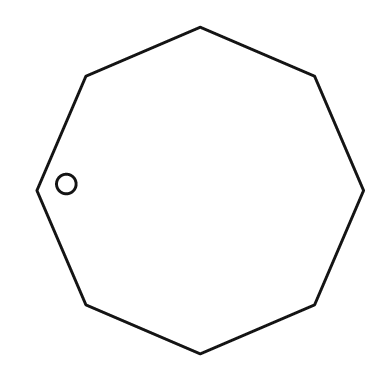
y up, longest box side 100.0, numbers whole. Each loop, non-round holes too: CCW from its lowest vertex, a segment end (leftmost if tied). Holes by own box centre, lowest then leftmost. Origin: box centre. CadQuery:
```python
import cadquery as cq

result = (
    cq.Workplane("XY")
    .moveTo(0.0, -50.0)
    .lineTo(35.0, -35.0)
    .lineTo(50.0, 0.0)
    .lineTo(35.0, 35.0)
    .lineTo(0.0, 50.0)
    .lineTo(-35.0, 35.0)
    .lineTo(-50.0, 0.0)
    .lineTo(-35.0, -35.0)
    .close()
    .moveTo(-41.0, 2.0)
    .circle(3.0)
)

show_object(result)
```